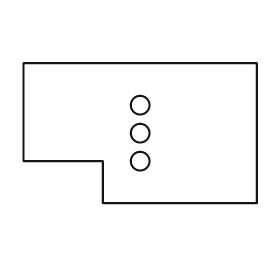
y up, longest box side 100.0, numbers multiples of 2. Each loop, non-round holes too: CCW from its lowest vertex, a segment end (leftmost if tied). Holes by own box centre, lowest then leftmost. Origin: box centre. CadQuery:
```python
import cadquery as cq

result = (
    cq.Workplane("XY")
    .moveTo(-16.0, -30.0)
    .lineTo(50.0, -30.0)
    .lineTo(50.0, 30.0)
    .lineTo(-50.0, 30.0)
    .lineTo(-50.0, -12.0)
    .lineTo(-16.0, -12.0)
    .close()
    .moveTo(0.0, -12.0)
    .circle(4.0)
    .moveTo(0.0, 0.0)
    .circle(4.0)
    .moveTo(0.0, 12.0)
    .circle(4.0)
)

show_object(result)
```